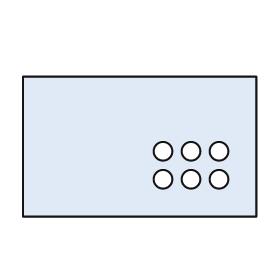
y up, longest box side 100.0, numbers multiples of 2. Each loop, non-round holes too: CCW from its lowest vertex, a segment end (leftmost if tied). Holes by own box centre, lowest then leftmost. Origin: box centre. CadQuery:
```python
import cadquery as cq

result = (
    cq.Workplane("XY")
    .moveTo(-50.0, -30.0)
    .lineTo(50.0, -30.0)
    .lineTo(50.0, 30.0)
    .lineTo(-50.0, 30.0)
    .close()
    .moveTo(10.0, -14.0)
    .circle(4.0)
    .moveTo(22.0, -14.0)
    .circle(4.0)
    .moveTo(34.0, -14.0)
    .circle(4.0)
    .moveTo(10.0, -2.0)
    .circle(4.0)
    .moveTo(22.0, -2.0)
    .circle(4.0)
    .moveTo(34.0, -2.0)
    .circle(4.0)
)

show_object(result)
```